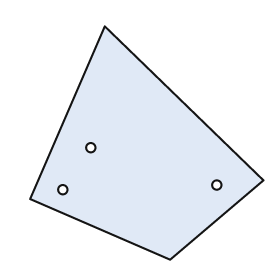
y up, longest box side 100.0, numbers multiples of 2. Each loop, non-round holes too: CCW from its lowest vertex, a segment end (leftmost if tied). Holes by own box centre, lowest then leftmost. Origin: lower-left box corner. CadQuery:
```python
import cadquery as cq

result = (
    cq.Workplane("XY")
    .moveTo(60.0, 0.0)
    .lineTo(100.0, 34.0)
    .lineTo(32.0, 100.0)
    .lineTo(0.0, 26.0)
    .close()
    .moveTo(14.0, 30.0)
    .circle(2.0)
    .moveTo(80.0, 32.0)
    .circle(2.0)
    .moveTo(26.0, 48.0)
    .circle(2.0)
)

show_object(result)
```